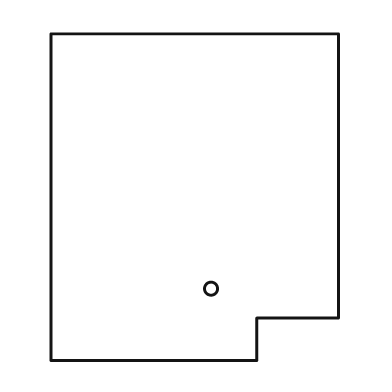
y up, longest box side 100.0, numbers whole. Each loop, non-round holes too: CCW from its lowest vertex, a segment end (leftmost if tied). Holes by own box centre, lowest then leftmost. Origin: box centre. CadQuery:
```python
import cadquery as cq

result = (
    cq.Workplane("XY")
    .moveTo(-44.0, -50.0)
    .lineTo(19.0, -50.0)
    .lineTo(19.0, -37.0)
    .lineTo(44.0, -37.0)
    .lineTo(44.0, 50.0)
    .lineTo(-44.0, 50.0)
    .close()
    .moveTo(5.0, -28.0)
    .circle(2.0)
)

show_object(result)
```